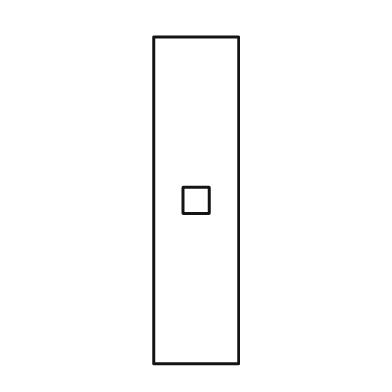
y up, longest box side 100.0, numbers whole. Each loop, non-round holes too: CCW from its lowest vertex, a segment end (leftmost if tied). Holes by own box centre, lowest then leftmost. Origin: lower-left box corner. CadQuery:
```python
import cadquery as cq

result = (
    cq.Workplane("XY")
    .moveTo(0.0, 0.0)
    .lineTo(26.0, 0.0)
    .lineTo(26.0, 100.0)
    .lineTo(0.0, 100.0)
    .close()
    .moveTo(9.0, 46.0)
    .lineTo(17.0, 46.0)
    .lineTo(17.0, 54.0)
    .lineTo(9.0, 54.0)
    .close()
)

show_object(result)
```